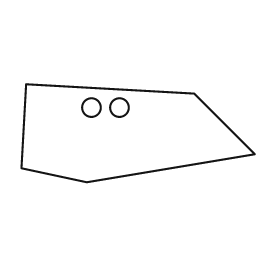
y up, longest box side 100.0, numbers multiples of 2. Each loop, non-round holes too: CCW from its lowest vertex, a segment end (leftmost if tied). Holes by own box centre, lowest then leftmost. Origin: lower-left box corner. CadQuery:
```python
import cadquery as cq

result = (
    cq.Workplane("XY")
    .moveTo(28.0, 0.0)
    .lineTo(100.0, 12.0)
    .lineTo(74.0, 38.0)
    .lineTo(2.0, 42.0)
    .lineTo(0.0, 6.0)
    .close()
    .moveTo(30.0, 32.0)
    .circle(4.0)
    .moveTo(42.0, 32.0)
    .circle(4.0)
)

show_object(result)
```